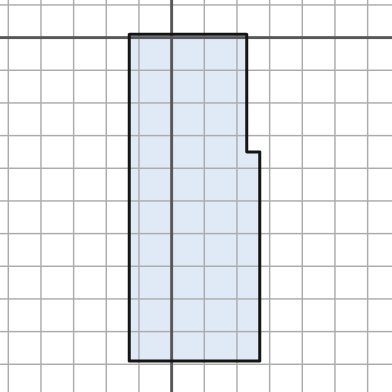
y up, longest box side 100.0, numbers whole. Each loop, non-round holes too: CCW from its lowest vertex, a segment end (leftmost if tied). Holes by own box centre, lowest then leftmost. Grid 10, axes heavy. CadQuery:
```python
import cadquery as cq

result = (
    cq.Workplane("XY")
    .moveTo(-13.0, -99.0)
    .lineTo(27.0, -99.0)
    .lineTo(27.0, -35.0)
    .lineTo(23.0, -35.0)
    .lineTo(23.0, 1.0)
    .lineTo(-13.0, 1.0)
    .close()
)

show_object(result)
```